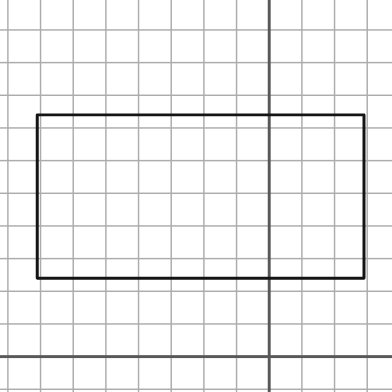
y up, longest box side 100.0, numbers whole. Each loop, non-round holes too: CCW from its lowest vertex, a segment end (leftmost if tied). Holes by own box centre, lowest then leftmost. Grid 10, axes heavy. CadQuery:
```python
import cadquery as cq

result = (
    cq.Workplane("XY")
    .moveTo(-71.0, 24.0)
    .lineTo(29.0, 24.0)
    .lineTo(29.0, 74.0)
    .lineTo(-71.0, 74.0)
    .close()
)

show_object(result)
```